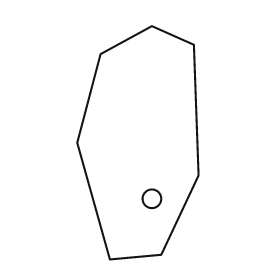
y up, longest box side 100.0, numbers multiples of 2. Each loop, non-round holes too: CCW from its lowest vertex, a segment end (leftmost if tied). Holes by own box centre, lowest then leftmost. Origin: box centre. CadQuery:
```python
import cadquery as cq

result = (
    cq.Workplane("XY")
    .moveTo(-12.0, -50.0)
    .lineTo(10.0, -48.0)
    .lineTo(26.0, -14.0)
    .lineTo(24.0, 42.0)
    .lineTo(6.0, 50.0)
    .lineTo(-16.0, 38.0)
    .lineTo(-26.0, 0.0)
    .close()
    .moveTo(6.0, -24.0)
    .circle(4.0)
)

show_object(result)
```